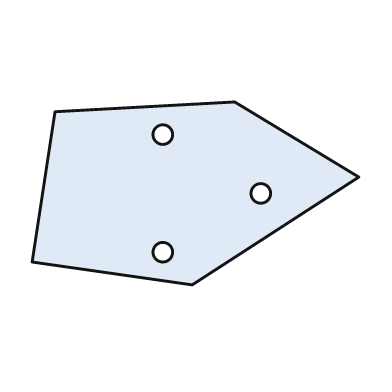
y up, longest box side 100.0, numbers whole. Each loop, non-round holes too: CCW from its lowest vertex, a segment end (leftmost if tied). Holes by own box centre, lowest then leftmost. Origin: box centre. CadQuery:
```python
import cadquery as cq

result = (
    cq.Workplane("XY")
    .moveTo(-1.0, -28.0)
    .lineTo(50.0, 5.0)
    .lineTo(12.0, 28.0)
    .lineTo(-43.0, 25.0)
    .lineTo(-50.0, -21.0)
    .close()
    .moveTo(-10.0, -18.0)
    .circle(3.0)
    .moveTo(20.0, 0.0)
    .circle(3.0)
    .moveTo(-10.0, 18.0)
    .circle(3.0)
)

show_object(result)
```